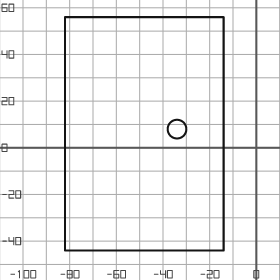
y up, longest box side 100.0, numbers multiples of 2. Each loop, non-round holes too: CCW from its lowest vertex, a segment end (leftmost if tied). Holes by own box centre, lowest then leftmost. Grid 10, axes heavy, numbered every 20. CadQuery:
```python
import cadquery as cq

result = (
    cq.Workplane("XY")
    .moveTo(-82.0, -44.0)
    .lineTo(-14.0, -44.0)
    .lineTo(-14.0, 56.0)
    .lineTo(-82.0, 56.0)
    .close()
    .moveTo(-34.0, 8.0)
    .circle(4.0)
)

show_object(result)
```